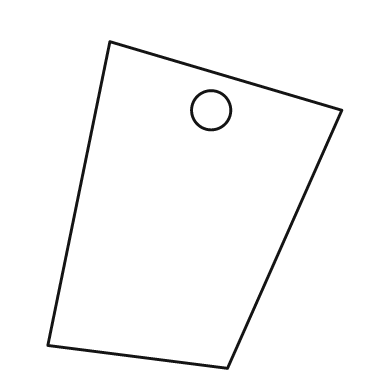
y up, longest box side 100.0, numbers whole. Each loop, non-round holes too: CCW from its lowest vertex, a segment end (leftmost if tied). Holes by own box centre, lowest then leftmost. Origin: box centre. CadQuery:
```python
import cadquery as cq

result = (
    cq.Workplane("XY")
    .moveTo(10.0, -50.0)
    .lineTo(45.0, 29.0)
    .lineTo(-26.0, 50.0)
    .lineTo(-45.0, -43.0)
    .close()
    .moveTo(5.0, 29.0)
    .circle(6.0)
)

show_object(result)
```